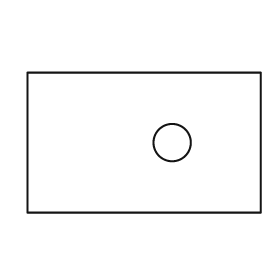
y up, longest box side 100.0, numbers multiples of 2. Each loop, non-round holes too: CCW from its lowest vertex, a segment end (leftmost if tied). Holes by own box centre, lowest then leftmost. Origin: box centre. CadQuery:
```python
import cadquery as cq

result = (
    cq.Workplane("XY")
    .moveTo(-50.0, -30.0)
    .lineTo(50.0, -30.0)
    .lineTo(50.0, 30.0)
    .lineTo(-50.0, 30.0)
    .close()
    .moveTo(12.0, 0.0)
    .circle(8.0)
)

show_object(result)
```